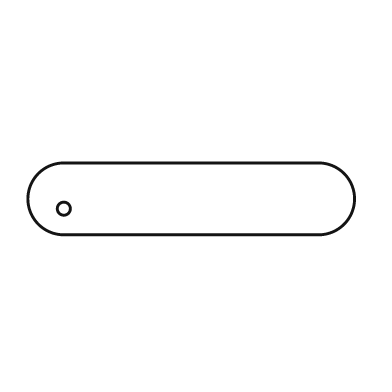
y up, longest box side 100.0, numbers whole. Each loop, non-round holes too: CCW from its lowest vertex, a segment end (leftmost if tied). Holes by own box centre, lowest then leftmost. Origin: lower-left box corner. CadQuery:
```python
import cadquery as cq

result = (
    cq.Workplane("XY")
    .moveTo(11.0, 0.0)
    .lineTo(89.0, 0.0)
    .threePointArc((100.0, 11.0), (89.0, 22.0))
    .lineTo(11.0, 22.0)
    .threePointArc((0.0, 11.0), (11.0, 0.0))
    .close()
    .moveTo(11.0, 8.0)
    .circle(2.0)
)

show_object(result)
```